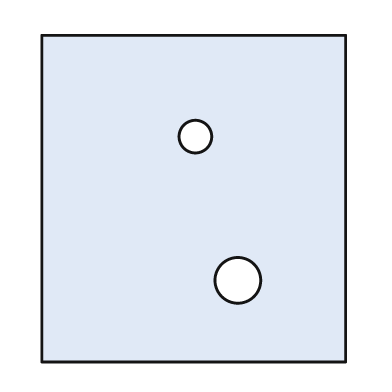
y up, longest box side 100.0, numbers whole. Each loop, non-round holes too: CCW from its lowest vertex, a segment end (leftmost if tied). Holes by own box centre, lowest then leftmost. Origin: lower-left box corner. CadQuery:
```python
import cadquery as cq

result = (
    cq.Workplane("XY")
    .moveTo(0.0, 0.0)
    .lineTo(93.0, 0.0)
    .lineTo(93.0, 100.0)
    .lineTo(0.0, 100.0)
    .close()
    .moveTo(60.0, 25.0)
    .circle(7.0)
    .moveTo(47.0, 69.0)
    .circle(5.0)
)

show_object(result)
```